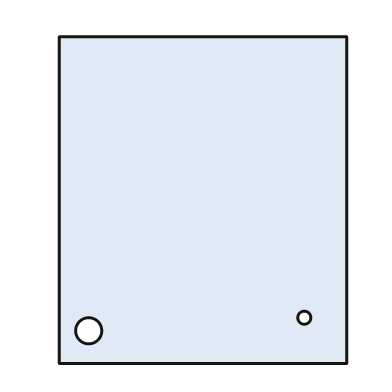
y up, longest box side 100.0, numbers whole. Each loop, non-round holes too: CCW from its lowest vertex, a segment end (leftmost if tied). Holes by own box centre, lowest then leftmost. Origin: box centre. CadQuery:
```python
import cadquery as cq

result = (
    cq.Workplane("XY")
    .moveTo(-44.0, -50.0)
    .lineTo(44.0, -50.0)
    .lineTo(44.0, 50.0)
    .lineTo(-44.0, 50.0)
    .close()
    .moveTo(-35.0, -40.0)
    .circle(4.0)
    .moveTo(31.0, -36.0)
    .circle(2.0)
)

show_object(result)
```